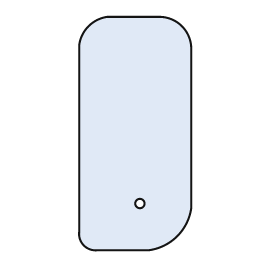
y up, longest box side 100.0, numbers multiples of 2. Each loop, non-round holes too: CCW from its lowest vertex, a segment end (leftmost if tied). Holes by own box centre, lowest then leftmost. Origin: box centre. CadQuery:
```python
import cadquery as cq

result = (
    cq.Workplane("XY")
    .moveTo(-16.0, -50.0)
    .lineTo(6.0, -50.0)
    .threePointArc((18.0, -44.0), (24.0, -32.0))
    .lineTo(24.0, 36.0)
    .threePointArc((20.0, 46.0), (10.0, 50.0))
    .lineTo(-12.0, 50.0)
    .threePointArc((-20.0, 46.0), (-24.0, 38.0))
    .lineTo(-24.0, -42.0)
    .threePointArc((-22.0, -48.0), (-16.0, -50.0))
    .close()
    .moveTo(2.0, -30.0)
    .circle(2.0)
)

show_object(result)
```